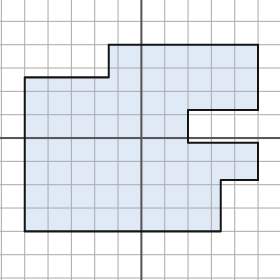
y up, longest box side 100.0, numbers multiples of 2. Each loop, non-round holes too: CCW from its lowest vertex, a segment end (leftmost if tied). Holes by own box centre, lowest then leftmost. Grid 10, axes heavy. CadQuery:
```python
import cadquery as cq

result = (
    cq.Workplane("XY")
    .moveTo(-50.0, -40.0)
    .lineTo(34.0, -40.0)
    .lineTo(34.0, -18.0)
    .lineTo(50.0, -18.0)
    .lineTo(50.0, -2.0)
    .lineTo(20.0, -2.0)
    .lineTo(20.0, 12.0)
    .lineTo(50.0, 12.0)
    .lineTo(50.0, 40.0)
    .lineTo(-14.0, 40.0)
    .lineTo(-14.0, 26.0)
    .lineTo(-50.0, 26.0)
    .close()
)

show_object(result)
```